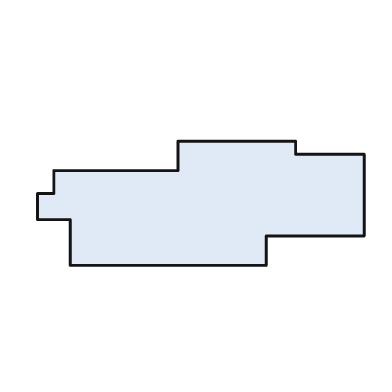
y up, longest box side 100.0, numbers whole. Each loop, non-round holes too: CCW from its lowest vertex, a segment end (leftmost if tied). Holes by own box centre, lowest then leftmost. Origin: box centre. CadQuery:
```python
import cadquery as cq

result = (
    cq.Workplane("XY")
    .moveTo(-40.0, -19.0)
    .lineTo(20.0, -19.0)
    .lineTo(20.0, -10.0)
    .lineTo(50.0, -10.0)
    .lineTo(50.0, 15.0)
    .lineTo(29.0, 15.0)
    .lineTo(29.0, 19.0)
    .lineTo(-7.0, 19.0)
    .lineTo(-7.0, 10.0)
    .lineTo(-45.0, 10.0)
    .lineTo(-45.0, 3.0)
    .lineTo(-50.0, 3.0)
    .lineTo(-50.0, -5.0)
    .lineTo(-40.0, -5.0)
    .close()
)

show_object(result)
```